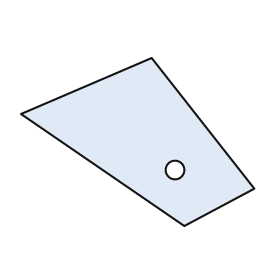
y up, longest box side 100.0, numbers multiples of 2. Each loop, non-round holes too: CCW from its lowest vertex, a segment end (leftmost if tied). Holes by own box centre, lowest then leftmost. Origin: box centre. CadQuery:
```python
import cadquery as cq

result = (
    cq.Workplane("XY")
    .moveTo(20.0, -36.0)
    .lineTo(50.0, -20.0)
    .lineTo(6.0, 36.0)
    .lineTo(-50.0, 12.0)
    .close()
    .moveTo(16.0, -12.0)
    .circle(4.0)
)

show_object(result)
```